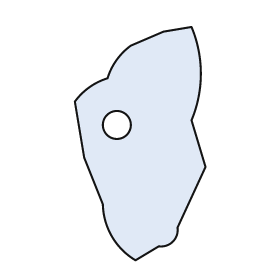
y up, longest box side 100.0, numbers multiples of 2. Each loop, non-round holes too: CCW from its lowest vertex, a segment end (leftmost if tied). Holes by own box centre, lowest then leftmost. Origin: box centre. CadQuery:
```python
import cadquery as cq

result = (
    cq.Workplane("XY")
    .moveTo(-2.0, -50.0)
    .lineTo(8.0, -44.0)
    .threePointArc((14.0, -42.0), (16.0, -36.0))
    .lineTo(28.0, -10.0)
    .lineTo(22.0, 10.0)
    .threePointArc((26.0, 30.0), (22.0, 50.0))
    .lineTo(10.0, 48.0)
    .lineTo(-4.0, 42.0)
    .threePointArc((-10.0, 36.0), (-14.0, 28.0))
    .threePointArc((-22.0, 24.0), (-28.0, 18.0))
    .lineTo(-24.0, -6.0)
    .lineTo(-16.0, -26.0)
    .threePointArc((-12.0, -40.0), (-2.0, -50.0))
    .close()
    .moveTo(-10.0, 8.0)
    .circle(6.0)
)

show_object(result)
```